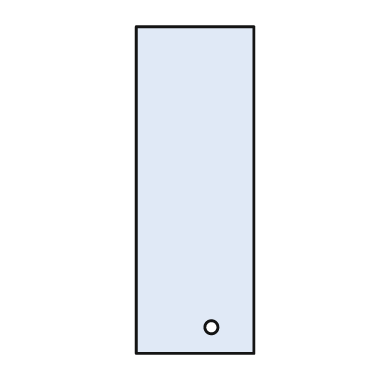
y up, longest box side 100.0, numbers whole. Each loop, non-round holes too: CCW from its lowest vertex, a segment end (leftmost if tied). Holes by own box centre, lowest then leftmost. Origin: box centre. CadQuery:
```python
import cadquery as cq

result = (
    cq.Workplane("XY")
    .moveTo(-18.0, -50.0)
    .lineTo(18.0, -50.0)
    .lineTo(18.0, 50.0)
    .lineTo(-18.0, 50.0)
    .close()
    .moveTo(5.0, -42.0)
    .circle(2.0)
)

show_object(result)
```